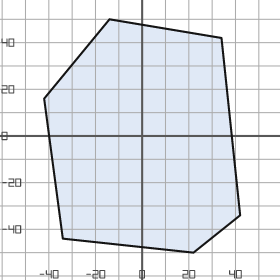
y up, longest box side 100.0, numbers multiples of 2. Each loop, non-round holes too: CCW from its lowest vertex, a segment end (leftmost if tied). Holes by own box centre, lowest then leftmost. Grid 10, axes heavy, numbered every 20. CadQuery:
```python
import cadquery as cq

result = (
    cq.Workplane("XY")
    .moveTo(22.0, -50.0)
    .lineTo(42.0, -34.0)
    .lineTo(34.0, 42.0)
    .lineTo(-14.0, 50.0)
    .lineTo(-42.0, 16.0)
    .lineTo(-34.0, -44.0)
    .close()
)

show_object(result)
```